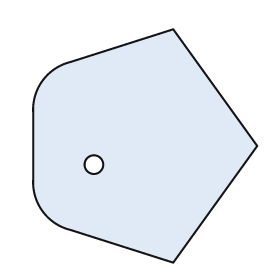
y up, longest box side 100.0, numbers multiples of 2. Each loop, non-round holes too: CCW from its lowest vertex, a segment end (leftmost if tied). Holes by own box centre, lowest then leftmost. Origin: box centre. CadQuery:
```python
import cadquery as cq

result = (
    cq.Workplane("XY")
    .moveTo(12.0, -50.0)
    .lineTo(48.0, 0.0)
    .lineTo(12.0, 50.0)
    .lineTo(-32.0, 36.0)
    .threePointArc((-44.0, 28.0), (-48.0, 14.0))
    .lineTo(-48.0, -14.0)
    .threePointArc((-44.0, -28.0), (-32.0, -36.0))
    .close()
    .moveTo(-22.0, -8.0)
    .circle(4.0)
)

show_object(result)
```